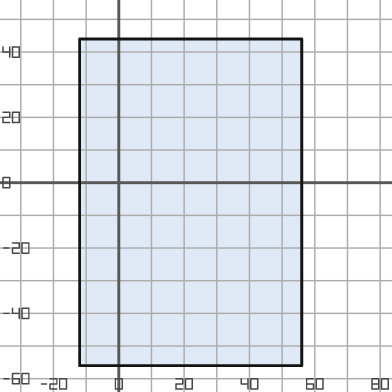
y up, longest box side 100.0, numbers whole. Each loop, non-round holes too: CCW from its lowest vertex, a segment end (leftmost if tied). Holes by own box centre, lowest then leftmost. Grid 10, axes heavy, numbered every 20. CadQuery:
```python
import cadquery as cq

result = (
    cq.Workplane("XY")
    .moveTo(-12.0, -56.0)
    .lineTo(56.0, -56.0)
    .lineTo(56.0, 44.0)
    .lineTo(-12.0, 44.0)
    .close()
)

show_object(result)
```